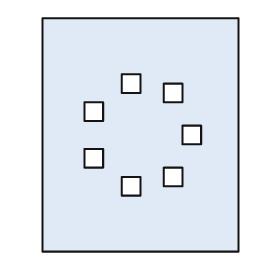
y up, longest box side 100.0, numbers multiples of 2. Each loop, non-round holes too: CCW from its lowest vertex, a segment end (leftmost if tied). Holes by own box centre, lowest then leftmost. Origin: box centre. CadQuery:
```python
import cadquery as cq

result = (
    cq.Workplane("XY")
    .moveTo(-42.0, -50.0)
    .lineTo(42.0, -50.0)
    .lineTo(42.0, 50.0)
    .lineTo(-42.0, 50.0)
    .close()
    .moveTo(-8.0, -26.0)
    .lineTo(0.0, -26.0)
    .lineTo(0.0, -18.0)
    .lineTo(-8.0, -18.0)
    .close()
    .moveTo(10.0, -22.0)
    .lineTo(18.0, -22.0)
    .lineTo(18.0, -14.0)
    .lineTo(10.0, -14.0)
    .close()
    .moveTo(-24.0, -14.0)
    .lineTo(-16.0, -14.0)
    .lineTo(-16.0, -6.0)
    .lineTo(-24.0, -6.0)
    .close()
    .moveTo(18.0, -4.0)
    .lineTo(26.0, -4.0)
    .lineTo(26.0, 4.0)
    .lineTo(18.0, 4.0)
    .close()
    .moveTo(-24.0, 6.0)
    .lineTo(-16.0, 6.0)
    .lineTo(-16.0, 14.0)
    .lineTo(-24.0, 14.0)
    .close()
    .moveTo(10.0, 14.0)
    .lineTo(18.0, 14.0)
    .lineTo(18.0, 22.0)
    .lineTo(10.0, 22.0)
    .close()
    .moveTo(-8.0, 18.0)
    .lineTo(0.0, 18.0)
    .lineTo(0.0, 26.0)
    .lineTo(-8.0, 26.0)
    .close()
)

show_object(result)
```